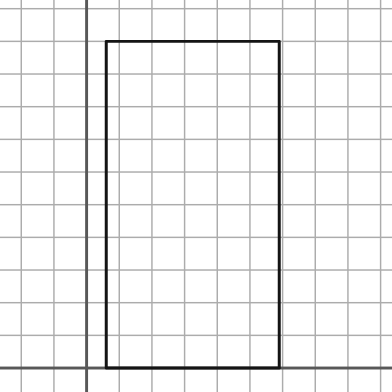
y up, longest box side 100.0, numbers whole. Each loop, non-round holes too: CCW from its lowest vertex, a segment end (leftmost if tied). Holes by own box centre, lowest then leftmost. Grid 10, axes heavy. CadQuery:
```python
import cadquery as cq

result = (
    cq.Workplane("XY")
    .moveTo(6.0, 0.0)
    .lineTo(59.0, 0.0)
    .lineTo(59.0, 100.0)
    .lineTo(6.0, 100.0)
    .close()
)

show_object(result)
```